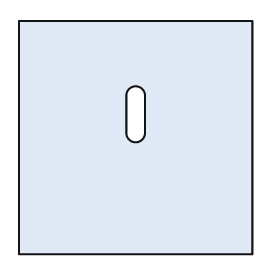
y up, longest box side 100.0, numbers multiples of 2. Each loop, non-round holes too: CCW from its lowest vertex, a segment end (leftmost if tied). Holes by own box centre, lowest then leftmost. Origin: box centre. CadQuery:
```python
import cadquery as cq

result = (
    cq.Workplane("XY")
    .moveTo(-50.0, -50.0)
    .lineTo(50.0, -50.0)
    .lineTo(50.0, 50.0)
    .lineTo(-50.0, 50.0)
    .close()
    .moveTo(-4.0, 2.0)
    .threePointArc((0.0, -2.0), (4.0, 2.0))
    .lineTo(4.0, 18.0)
    .threePointArc((0.0, 22.0), (-4.0, 18.0))
    .close()
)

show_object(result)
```